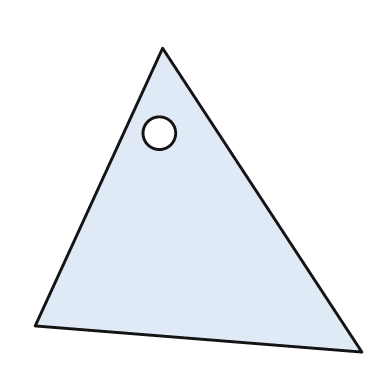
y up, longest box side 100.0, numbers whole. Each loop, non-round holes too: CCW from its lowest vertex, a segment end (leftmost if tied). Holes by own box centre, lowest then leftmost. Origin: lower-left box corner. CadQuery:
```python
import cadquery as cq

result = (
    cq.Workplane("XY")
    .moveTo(100.0, 0.0)
    .lineTo(39.0, 93.0)
    .lineTo(0.0, 8.0)
    .close()
    .moveTo(38.0, 67.0)
    .circle(5.0)
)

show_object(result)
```